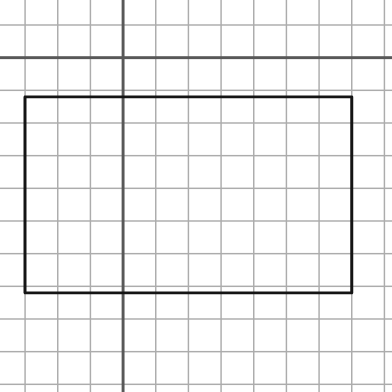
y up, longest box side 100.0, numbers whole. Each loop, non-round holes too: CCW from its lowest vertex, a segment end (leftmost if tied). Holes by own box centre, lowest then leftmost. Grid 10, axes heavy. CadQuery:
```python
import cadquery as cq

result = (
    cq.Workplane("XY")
    .moveTo(-30.0, -72.0)
    .lineTo(70.0, -72.0)
    .lineTo(70.0, -12.0)
    .lineTo(-30.0, -12.0)
    .close()
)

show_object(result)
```